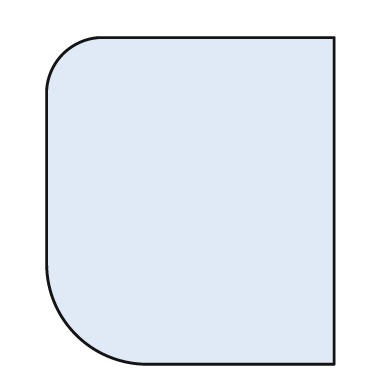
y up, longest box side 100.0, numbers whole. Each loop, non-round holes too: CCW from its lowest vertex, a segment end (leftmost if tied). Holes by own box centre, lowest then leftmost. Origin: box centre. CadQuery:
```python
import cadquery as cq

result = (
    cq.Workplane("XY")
    .moveTo(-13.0, -50.0)
    .lineTo(44.0, -50.0)
    .lineTo(44.0, 50.0)
    .lineTo(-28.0, 50.0)
    .threePointArc((-39.0, 45.0), (-44.0, 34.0))
    .lineTo(-44.0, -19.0)
    .threePointArc((-35.0, -41.0), (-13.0, -50.0))
    .close()
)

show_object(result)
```